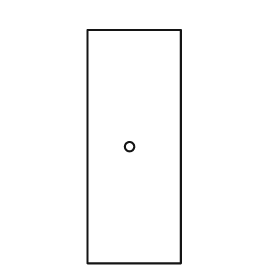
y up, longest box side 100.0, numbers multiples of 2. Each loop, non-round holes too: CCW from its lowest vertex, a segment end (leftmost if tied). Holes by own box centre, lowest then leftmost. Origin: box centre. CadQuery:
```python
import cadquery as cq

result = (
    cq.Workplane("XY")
    .moveTo(-20.0, -50.0)
    .lineTo(20.0, -50.0)
    .lineTo(20.0, 50.0)
    .lineTo(-20.0, 50.0)
    .close()
    .moveTo(-2.0, 0.0)
    .circle(2.0)
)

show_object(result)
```